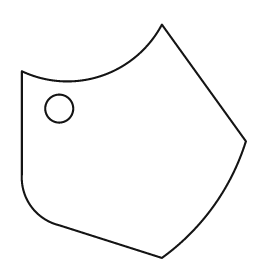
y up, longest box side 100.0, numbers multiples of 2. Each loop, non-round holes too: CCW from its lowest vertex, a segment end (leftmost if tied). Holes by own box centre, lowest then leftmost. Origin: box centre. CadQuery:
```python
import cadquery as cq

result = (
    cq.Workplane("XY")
    .moveTo(12.0, -50.0)
    .threePointArc((34.0, -28.0), (48.0, 0.0))
    .lineTo(12.0, 50.0)
    .threePointArc((-14.0, 28.0), (-48.0, 30.0))
    .lineTo(-48.0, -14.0)
    .threePointArc((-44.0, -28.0), (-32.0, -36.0))
    .close()
    .moveTo(-32.0, 14.0)
    .circle(6.0)
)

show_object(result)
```